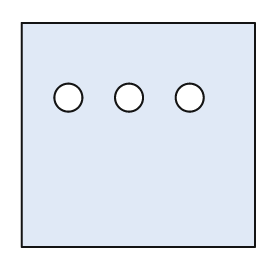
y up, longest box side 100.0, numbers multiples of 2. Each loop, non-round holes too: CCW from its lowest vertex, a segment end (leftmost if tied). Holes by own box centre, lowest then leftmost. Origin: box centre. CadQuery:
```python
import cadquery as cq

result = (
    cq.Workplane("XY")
    .moveTo(-50.0, -48.0)
    .lineTo(50.0, -48.0)
    .lineTo(50.0, 48.0)
    .lineTo(-50.0, 48.0)
    .close()
    .moveTo(-30.0, 16.0)
    .circle(6.0)
    .moveTo(-4.0, 16.0)
    .circle(6.0)
    .moveTo(22.0, 16.0)
    .circle(6.0)
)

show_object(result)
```